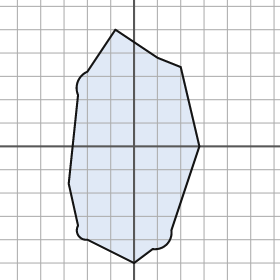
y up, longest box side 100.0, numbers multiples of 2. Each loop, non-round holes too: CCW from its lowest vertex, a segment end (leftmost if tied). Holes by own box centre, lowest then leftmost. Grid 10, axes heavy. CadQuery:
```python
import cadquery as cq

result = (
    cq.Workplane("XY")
    .moveTo(0.0, -50.0)
    .lineTo(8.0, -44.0)
    .threePointArc((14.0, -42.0), (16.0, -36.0))
    .lineTo(28.0, 0.0)
    .lineTo(20.0, 34.0)
    .lineTo(10.0, 38.0)
    .lineTo(-8.0, 50.0)
    .lineTo(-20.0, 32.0)
    .threePointArc((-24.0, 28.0), (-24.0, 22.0))
    .lineTo(-28.0, -16.0)
    .lineTo(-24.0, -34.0)
    .threePointArc((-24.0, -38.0), (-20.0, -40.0))
    .close()
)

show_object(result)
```